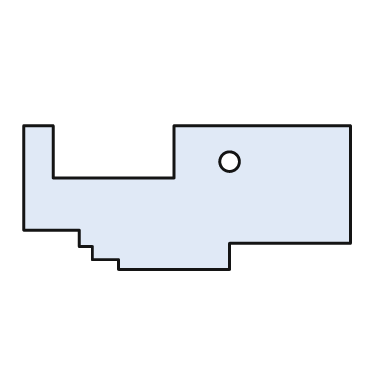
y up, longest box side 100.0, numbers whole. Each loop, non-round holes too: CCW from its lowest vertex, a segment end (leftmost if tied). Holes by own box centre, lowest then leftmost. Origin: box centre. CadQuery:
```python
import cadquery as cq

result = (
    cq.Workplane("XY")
    .moveTo(-21.0, -22.0)
    .lineTo(13.0, -22.0)
    .lineTo(13.0, -14.0)
    .lineTo(50.0, -14.0)
    .lineTo(50.0, 22.0)
    .lineTo(-4.0, 22.0)
    .lineTo(-4.0, 6.0)
    .lineTo(-41.0, 6.0)
    .lineTo(-41.0, 22.0)
    .lineTo(-50.0, 22.0)
    .lineTo(-50.0, -10.0)
    .lineTo(-33.0, -10.0)
    .lineTo(-33.0, -15.0)
    .lineTo(-29.0, -15.0)
    .lineTo(-29.0, -19.0)
    .lineTo(-21.0, -19.0)
    .close()
    .moveTo(13.0, 11.0)
    .circle(3.0)
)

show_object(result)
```